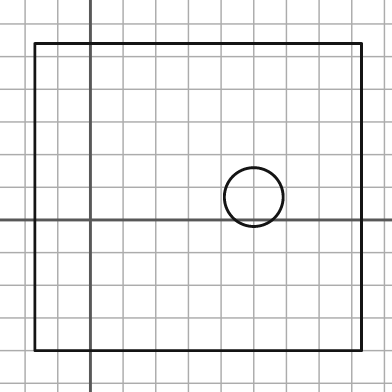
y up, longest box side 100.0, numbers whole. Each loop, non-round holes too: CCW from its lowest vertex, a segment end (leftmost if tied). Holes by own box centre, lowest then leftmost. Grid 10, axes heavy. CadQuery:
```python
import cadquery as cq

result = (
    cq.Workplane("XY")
    .moveTo(-17.0, -40.0)
    .lineTo(83.0, -40.0)
    .lineTo(83.0, 54.0)
    .lineTo(-17.0, 54.0)
    .close()
    .moveTo(50.0, 7.0)
    .circle(9.0)
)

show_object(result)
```